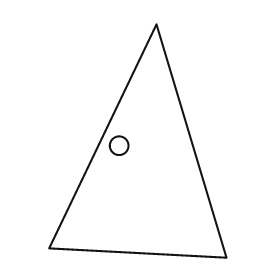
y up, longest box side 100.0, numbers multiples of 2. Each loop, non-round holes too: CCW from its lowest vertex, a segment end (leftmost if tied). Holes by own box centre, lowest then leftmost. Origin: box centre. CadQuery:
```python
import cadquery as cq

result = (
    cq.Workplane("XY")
    .moveTo(38.0, -50.0)
    .lineTo(8.0, 50.0)
    .lineTo(-38.0, -46.0)
    .close()
    .moveTo(-8.0, -2.0)
    .circle(4.0)
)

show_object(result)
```